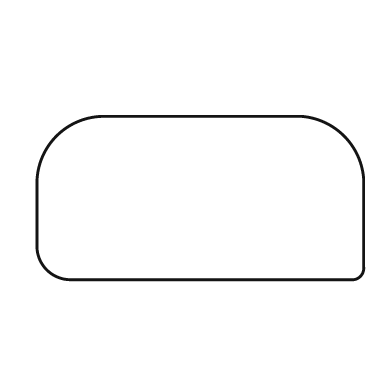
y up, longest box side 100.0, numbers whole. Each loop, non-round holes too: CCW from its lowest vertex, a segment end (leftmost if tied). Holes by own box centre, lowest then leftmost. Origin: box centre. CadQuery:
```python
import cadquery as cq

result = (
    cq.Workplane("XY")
    .moveTo(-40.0, -25.0)
    .lineTo(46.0, -25.0)
    .threePointArc((49.0, -24.0), (50.0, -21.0))
    .lineTo(50.0, 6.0)
    .threePointArc((44.0, 19.0), (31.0, 25.0))
    .lineTo(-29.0, 25.0)
    .threePointArc((-44.0, 19.0), (-50.0, 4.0))
    .lineTo(-50.0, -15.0)
    .threePointArc((-47.0, -22.0), (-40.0, -25.0))
    .close()
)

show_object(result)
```